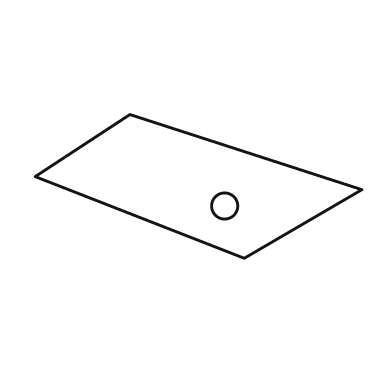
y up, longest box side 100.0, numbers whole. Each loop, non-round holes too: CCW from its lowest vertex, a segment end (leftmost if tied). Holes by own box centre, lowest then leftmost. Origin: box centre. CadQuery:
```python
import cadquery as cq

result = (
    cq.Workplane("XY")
    .moveTo(14.0, -22.0)
    .lineTo(50.0, -1.0)
    .lineTo(-21.0, 22.0)
    .lineTo(-50.0, 3.0)
    .close()
    .moveTo(8.0, -6.0)
    .circle(4.0)
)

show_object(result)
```